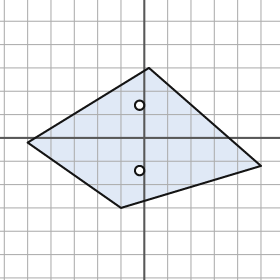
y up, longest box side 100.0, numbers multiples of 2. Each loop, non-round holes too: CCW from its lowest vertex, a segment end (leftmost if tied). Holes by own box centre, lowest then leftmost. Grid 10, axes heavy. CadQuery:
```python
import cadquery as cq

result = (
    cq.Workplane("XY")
    .moveTo(-10.0, -30.0)
    .lineTo(50.0, -12.0)
    .lineTo(2.0, 30.0)
    .lineTo(-50.0, -2.0)
    .close()
    .moveTo(-2.0, -14.0)
    .circle(2.0)
    .moveTo(-2.0, 14.0)
    .circle(2.0)
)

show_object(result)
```